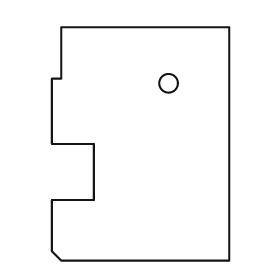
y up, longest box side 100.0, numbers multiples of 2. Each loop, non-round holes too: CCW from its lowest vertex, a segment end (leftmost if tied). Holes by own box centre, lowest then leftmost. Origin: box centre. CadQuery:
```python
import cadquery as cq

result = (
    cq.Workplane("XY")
    .moveTo(-34.0, -50.0)
    .lineTo(38.0, -50.0)
    .lineTo(38.0, 50.0)
    .lineTo(-34.0, 50.0)
    .lineTo(-34.0, 28.0)
    .lineTo(-38.0, 28.0)
    .lineTo(-38.0, 0.0)
    .lineTo(-20.0, 0.0)
    .lineTo(-20.0, -24.0)
    .lineTo(-38.0, -24.0)
    .lineTo(-38.0, -46.0)
    .close()
    .moveTo(12.0, 26.0)
    .circle(4.0)
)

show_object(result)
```